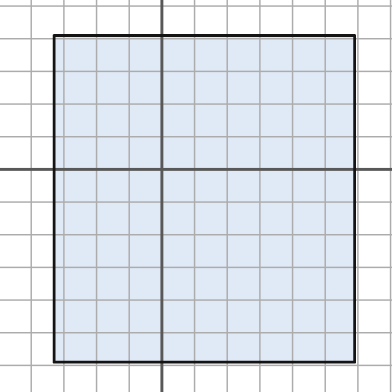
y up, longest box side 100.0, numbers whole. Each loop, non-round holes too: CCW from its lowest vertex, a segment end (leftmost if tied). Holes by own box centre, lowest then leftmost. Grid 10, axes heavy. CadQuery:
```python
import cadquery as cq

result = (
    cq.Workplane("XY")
    .moveTo(-33.0, -59.0)
    .lineTo(59.0, -59.0)
    .lineTo(59.0, 41.0)
    .lineTo(-33.0, 41.0)
    .close()
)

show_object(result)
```